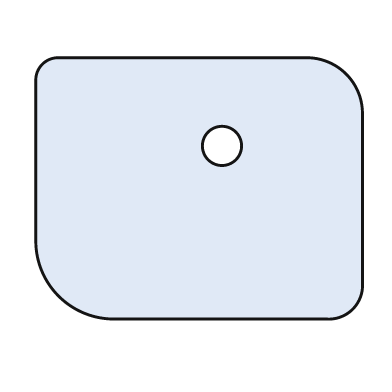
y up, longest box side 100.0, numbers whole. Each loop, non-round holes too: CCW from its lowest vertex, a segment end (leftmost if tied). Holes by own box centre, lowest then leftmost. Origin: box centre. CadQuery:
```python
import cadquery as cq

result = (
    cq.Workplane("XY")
    .moveTo(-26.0, -40.0)
    .lineTo(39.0, -40.0)
    .threePointArc((47.0, -37.0), (50.0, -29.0))
    .lineTo(50.0, 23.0)
    .threePointArc((45.0, 35.0), (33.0, 40.0))
    .lineTo(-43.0, 40.0)
    .threePointArc((-48.0, 38.0), (-50.0, 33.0))
    .lineTo(-50.0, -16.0)
    .threePointArc((-43.0, -33.0), (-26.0, -40.0))
    .close()
    .moveTo(7.0, 13.0)
    .circle(6.0)
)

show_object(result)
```